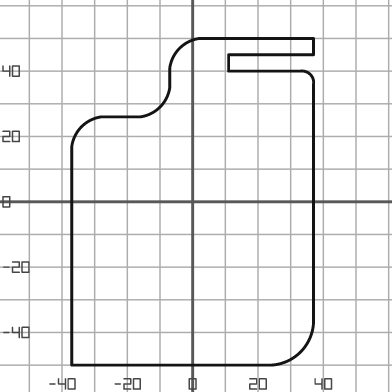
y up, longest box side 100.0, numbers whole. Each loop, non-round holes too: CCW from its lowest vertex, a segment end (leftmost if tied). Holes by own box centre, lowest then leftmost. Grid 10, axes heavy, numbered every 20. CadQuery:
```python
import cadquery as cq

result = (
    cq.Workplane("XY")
    .moveTo(-37.0, -50.0)
    .lineTo(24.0, -50.0)
    .threePointArc((33.0, -46.0), (37.0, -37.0))
    .lineTo(37.0, 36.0)
    .threePointArc((36.0, 39.0), (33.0, 40.0))
    .lineTo(11.0, 40.0)
    .lineTo(11.0, 45.0)
    .lineTo(37.0, 45.0)
    .lineTo(37.0, 50.0)
    .lineTo(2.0, 50.0)
    .threePointArc((-4.0, 47.0), (-7.0, 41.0))
    .lineTo(-7.0, 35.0)
    .threePointArc((-10.0, 29.0), (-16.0, 26.0))
    .lineTo(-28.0, 26.0)
    .threePointArc((-34.0, 23.0), (-37.0, 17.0))
    .close()
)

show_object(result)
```